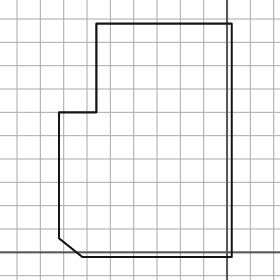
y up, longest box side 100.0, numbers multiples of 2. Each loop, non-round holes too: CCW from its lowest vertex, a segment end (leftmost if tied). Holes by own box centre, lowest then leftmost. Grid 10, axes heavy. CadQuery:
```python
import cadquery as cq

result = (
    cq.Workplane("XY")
    .moveTo(-62.0, -2.0)
    .lineTo(2.0, -2.0)
    .lineTo(2.0, 98.0)
    .lineTo(-56.0, 98.0)
    .lineTo(-56.0, 60.0)
    .lineTo(-72.0, 60.0)
    .lineTo(-72.0, 6.0)
    .close()
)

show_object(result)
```